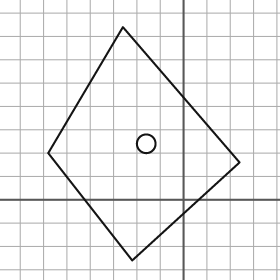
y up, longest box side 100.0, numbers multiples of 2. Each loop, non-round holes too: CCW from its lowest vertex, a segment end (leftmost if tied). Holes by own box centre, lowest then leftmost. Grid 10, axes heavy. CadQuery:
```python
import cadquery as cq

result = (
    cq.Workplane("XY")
    .moveTo(-22.0, -26.0)
    .lineTo(24.0, 16.0)
    .lineTo(-26.0, 74.0)
    .lineTo(-58.0, 20.0)
    .close()
    .moveTo(-16.0, 24.0)
    .circle(4.0)
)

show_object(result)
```